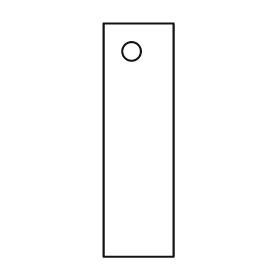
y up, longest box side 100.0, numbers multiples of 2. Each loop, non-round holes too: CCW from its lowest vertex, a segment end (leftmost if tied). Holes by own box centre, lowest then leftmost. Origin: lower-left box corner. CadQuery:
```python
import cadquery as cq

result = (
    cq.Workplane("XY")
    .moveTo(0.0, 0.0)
    .lineTo(30.0, 0.0)
    .lineTo(30.0, 100.0)
    .lineTo(0.0, 100.0)
    .close()
    .moveTo(12.0, 88.0)
    .circle(4.0)
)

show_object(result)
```